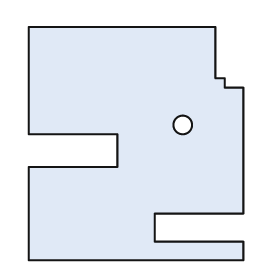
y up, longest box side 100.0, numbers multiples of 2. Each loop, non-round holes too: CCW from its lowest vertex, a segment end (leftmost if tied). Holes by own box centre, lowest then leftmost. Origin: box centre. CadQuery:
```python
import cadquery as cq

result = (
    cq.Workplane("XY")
    .moveTo(-46.0, -50.0)
    .lineTo(46.0, -50.0)
    .lineTo(46.0, -42.0)
    .lineTo(8.0, -42.0)
    .lineTo(8.0, -30.0)
    .lineTo(46.0, -30.0)
    .lineTo(46.0, 24.0)
    .lineTo(38.0, 24.0)
    .lineTo(38.0, 28.0)
    .lineTo(34.0, 28.0)
    .lineTo(34.0, 50.0)
    .lineTo(-46.0, 50.0)
    .lineTo(-46.0, 4.0)
    .lineTo(-8.0, 4.0)
    .lineTo(-8.0, -10.0)
    .lineTo(-46.0, -10.0)
    .close()
    .moveTo(20.0, 8.0)
    .circle(4.0)
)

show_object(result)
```